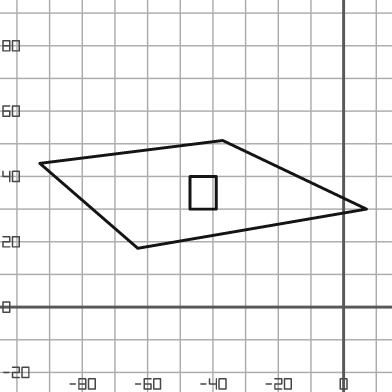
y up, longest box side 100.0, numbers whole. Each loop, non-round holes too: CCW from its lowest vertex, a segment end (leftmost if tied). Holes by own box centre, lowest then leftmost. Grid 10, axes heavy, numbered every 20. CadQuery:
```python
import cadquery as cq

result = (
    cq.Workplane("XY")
    .moveTo(-63.0, 18.0)
    .lineTo(7.0, 30.0)
    .lineTo(-37.0, 51.0)
    .lineTo(-93.0, 44.0)
    .close()
    .moveTo(-47.0, 30.0)
    .lineTo(-39.0, 30.0)
    .lineTo(-39.0, 40.0)
    .lineTo(-47.0, 40.0)
    .close()
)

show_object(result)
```